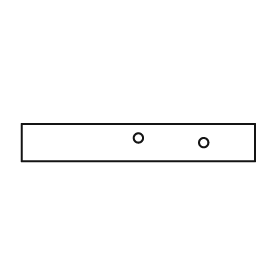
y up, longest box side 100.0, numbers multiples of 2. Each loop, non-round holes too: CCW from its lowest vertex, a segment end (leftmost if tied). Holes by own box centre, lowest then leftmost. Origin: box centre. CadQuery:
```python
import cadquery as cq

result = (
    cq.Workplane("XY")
    .moveTo(-50.0, -8.0)
    .lineTo(50.0, -8.0)
    .lineTo(50.0, 8.0)
    .lineTo(-50.0, 8.0)
    .close()
    .moveTo(28.0, 0.0)
    .circle(2.0)
    .moveTo(0.0, 2.0)
    .circle(2.0)
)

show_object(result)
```